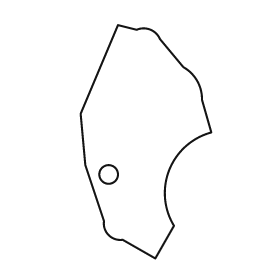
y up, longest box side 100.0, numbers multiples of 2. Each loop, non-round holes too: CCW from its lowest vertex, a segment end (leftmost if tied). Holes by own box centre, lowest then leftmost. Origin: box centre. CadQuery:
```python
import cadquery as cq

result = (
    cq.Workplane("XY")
    .moveTo(4.0, -50.0)
    .lineTo(12.0, -36.0)
    .threePointArc((10.0, -12.0), (28.0, 4.0))
    .lineTo(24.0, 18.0)
    .threePointArc((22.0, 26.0), (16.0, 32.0))
    .lineTo(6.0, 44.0)
    .threePointArc((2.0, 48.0), (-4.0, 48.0))
    .lineTo(-12.0, 50.0)
    .lineTo(-28.0, 12.0)
    .lineTo(-26.0, -10.0)
    .lineTo(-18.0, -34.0)
    .threePointArc((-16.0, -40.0), (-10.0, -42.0))
    .close()
    .moveTo(-16.0, -14.0)
    .circle(4.0)
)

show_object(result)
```